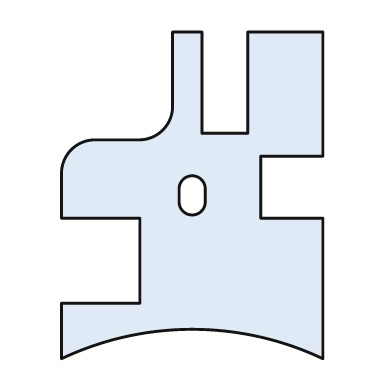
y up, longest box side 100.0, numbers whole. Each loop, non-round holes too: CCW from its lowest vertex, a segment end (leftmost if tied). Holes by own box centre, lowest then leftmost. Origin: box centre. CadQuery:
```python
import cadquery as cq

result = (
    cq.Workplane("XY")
    .moveTo(-40.0, -50.0)
    .threePointArc((0.0, -41.0), (40.0, -50.0))
    .lineTo(40.0, -7.0)
    .lineTo(21.0, -7.0)
    .lineTo(21.0, 12.0)
    .lineTo(40.0, 12.0)
    .lineTo(40.0, 50.0)
    .lineTo(17.0, 50.0)
    .lineTo(17.0, 19.0)
    .lineTo(3.0, 19.0)
    .lineTo(3.0, 50.0)
    .lineTo(-6.0, 50.0)
    .lineTo(-6.0, 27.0)
    .threePointArc((-9.0, 20.0), (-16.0, 17.0))
    .lineTo(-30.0, 17.0)
    .threePointArc((-37.0, 14.0), (-40.0, 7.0))
    .lineTo(-40.0, -7.0)
    .lineTo(-16.0, -7.0)
    .lineTo(-16.0, -33.0)
    .lineTo(-40.0, -33.0)
    .close()
    .moveTo(-4.0, -2.0)
    .threePointArc((0.0, -6.0), (4.0, -2.0))
    .lineTo(4.0, 2.0)
    .threePointArc((0.0, 6.0), (-4.0, 2.0))
    .close()
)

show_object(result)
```